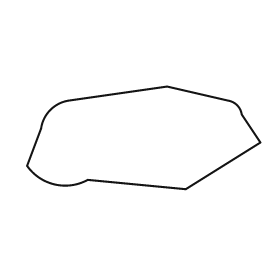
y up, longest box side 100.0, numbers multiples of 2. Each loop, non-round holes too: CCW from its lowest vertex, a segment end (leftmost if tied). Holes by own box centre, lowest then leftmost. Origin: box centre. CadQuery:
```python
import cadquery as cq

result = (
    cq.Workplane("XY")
    .moveTo(18.0, -22.0)
    .lineTo(50.0, -2.0)
    .lineTo(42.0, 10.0)
    .threePointArc((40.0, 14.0), (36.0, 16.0))
    .lineTo(10.0, 22.0)
    .lineTo(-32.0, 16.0)
    .threePointArc((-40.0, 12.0), (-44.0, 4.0))
    .lineTo(-50.0, -12.0)
    .threePointArc((-38.0, -20.0), (-24.0, -18.0))
    .close()
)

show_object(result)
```